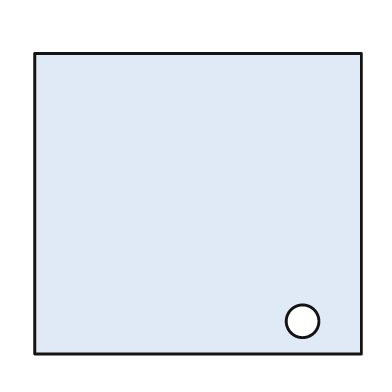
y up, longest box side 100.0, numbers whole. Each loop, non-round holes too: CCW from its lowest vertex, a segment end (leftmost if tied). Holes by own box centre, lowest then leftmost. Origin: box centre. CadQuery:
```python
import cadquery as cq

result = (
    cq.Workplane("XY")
    .moveTo(-50.0, -46.0)
    .lineTo(50.0, -46.0)
    .lineTo(50.0, 46.0)
    .lineTo(-50.0, 46.0)
    .close()
    .moveTo(32.0, -36.0)
    .circle(5.0)
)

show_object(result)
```